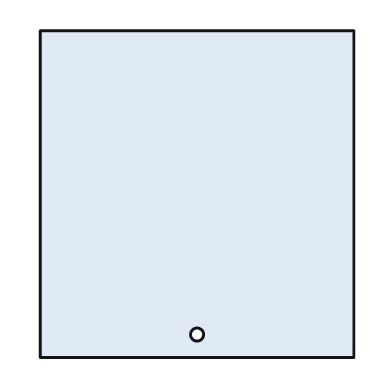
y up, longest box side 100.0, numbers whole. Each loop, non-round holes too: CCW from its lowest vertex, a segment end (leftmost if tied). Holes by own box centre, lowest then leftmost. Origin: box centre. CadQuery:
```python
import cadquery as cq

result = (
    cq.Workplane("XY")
    .moveTo(-48.0, -50.0)
    .lineTo(48.0, -50.0)
    .lineTo(48.0, 50.0)
    .lineTo(-48.0, 50.0)
    .close()
    .moveTo(0.0, -43.0)
    .circle(2.0)
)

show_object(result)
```